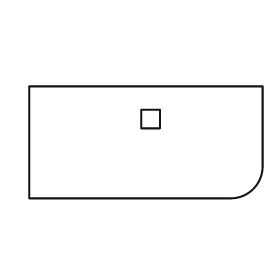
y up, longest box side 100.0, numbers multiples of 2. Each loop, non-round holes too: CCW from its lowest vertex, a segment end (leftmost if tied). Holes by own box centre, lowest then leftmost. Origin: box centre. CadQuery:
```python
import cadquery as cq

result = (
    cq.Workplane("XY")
    .moveTo(-50.0, -24.0)
    .lineTo(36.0, -24.0)
    .threePointArc((46.0, -20.0), (50.0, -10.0))
    .lineTo(50.0, 24.0)
    .lineTo(-50.0, 24.0)
    .close()
    .moveTo(-2.0, 6.0)
    .lineTo(6.0, 6.0)
    .lineTo(6.0, 14.0)
    .lineTo(-2.0, 14.0)
    .close()
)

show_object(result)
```